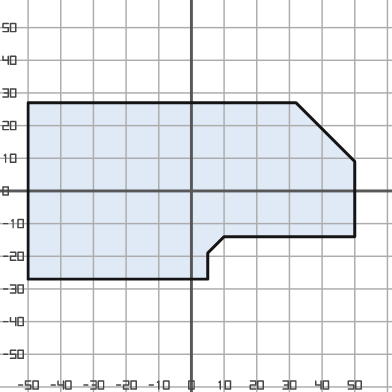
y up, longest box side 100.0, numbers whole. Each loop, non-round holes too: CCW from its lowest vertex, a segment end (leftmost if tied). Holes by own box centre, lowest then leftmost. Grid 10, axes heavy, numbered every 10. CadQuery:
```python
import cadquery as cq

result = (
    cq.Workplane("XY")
    .moveTo(-50.0, -27.0)
    .lineTo(5.0, -27.0)
    .lineTo(5.0, -19.0)
    .lineTo(10.0, -14.0)
    .lineTo(50.0, -14.0)
    .lineTo(50.0, 9.0)
    .lineTo(32.0, 27.0)
    .lineTo(-50.0, 27.0)
    .close()
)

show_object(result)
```